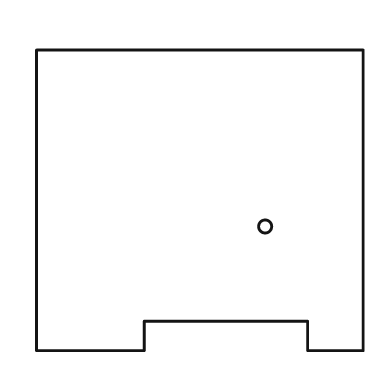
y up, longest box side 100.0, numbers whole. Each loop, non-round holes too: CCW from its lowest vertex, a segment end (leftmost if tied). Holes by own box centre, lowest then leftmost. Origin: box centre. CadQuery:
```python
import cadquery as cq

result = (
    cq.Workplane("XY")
    .moveTo(-50.0, -46.0)
    .lineTo(-17.0, -46.0)
    .lineTo(-17.0, -37.0)
    .lineTo(33.0, -37.0)
    .lineTo(33.0, -46.0)
    .lineTo(50.0, -46.0)
    .lineTo(50.0, 46.0)
    .lineTo(-50.0, 46.0)
    .close()
    .moveTo(20.0, -8.0)
    .circle(2.0)
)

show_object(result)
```